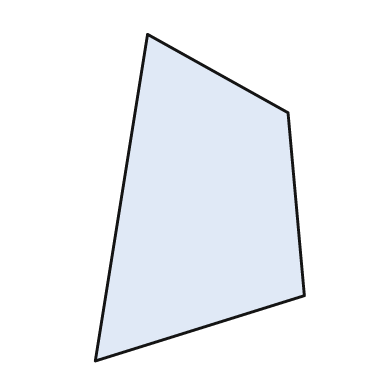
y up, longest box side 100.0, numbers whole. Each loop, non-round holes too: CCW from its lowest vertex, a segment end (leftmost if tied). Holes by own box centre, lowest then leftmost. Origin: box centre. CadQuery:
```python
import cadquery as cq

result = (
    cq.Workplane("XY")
    .moveTo(-32.0, -50.0)
    .lineTo(32.0, -30.0)
    .lineTo(27.0, 26.0)
    .lineTo(-16.0, 50.0)
    .close()
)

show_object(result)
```